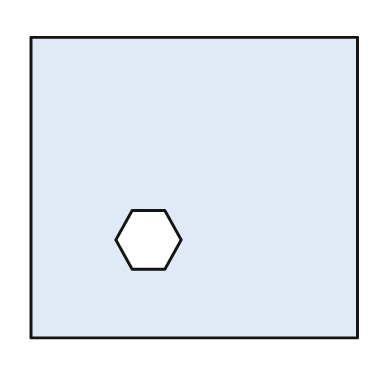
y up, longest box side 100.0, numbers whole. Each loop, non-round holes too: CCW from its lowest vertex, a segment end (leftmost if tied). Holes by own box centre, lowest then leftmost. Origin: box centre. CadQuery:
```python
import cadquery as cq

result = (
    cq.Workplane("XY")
    .moveTo(-50.0, -46.0)
    .lineTo(50.0, -46.0)
    .lineTo(50.0, 46.0)
    .lineTo(-50.0, 46.0)
    .close()
    .moveTo(-19.0, -25.0)
    .lineTo(-9.0, -25.0)
    .lineTo(-4.0, -16.0)
    .lineTo(-9.0, -7.0)
    .lineTo(-19.0, -7.0)
    .lineTo(-24.0, -16.0)
    .close()
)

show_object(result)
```